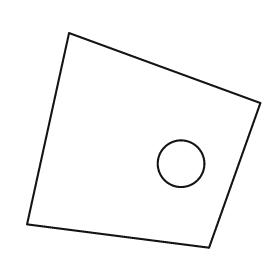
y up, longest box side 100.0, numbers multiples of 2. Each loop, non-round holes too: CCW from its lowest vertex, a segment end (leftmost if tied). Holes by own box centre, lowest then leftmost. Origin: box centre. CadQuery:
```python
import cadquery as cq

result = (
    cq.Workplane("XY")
    .moveTo(28.0, -46.0)
    .lineTo(50.0, 16.0)
    .lineTo(-32.0, 46.0)
    .lineTo(-50.0, -36.0)
    .close()
    .moveTo(16.0, -10.0)
    .circle(10.0)
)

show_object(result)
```